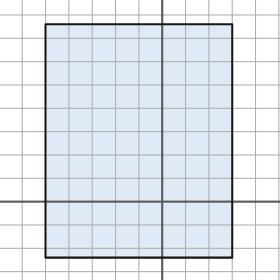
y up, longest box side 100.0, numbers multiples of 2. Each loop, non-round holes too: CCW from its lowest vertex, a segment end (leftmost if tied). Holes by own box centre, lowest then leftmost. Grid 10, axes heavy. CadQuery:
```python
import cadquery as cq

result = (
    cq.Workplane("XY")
    .moveTo(-50.0, -24.0)
    .lineTo(30.0, -24.0)
    .lineTo(30.0, 76.0)
    .lineTo(-50.0, 76.0)
    .close()
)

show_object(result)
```